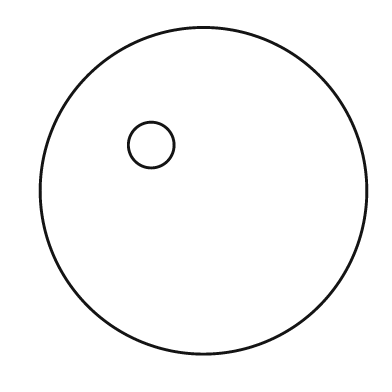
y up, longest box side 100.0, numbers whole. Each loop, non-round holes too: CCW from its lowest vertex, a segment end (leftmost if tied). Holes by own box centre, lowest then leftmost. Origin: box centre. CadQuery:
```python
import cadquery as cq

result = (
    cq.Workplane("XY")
    .moveTo(0.0, 0.0)
    .circle(50.0)
    .moveTo(-16.0, 14.0)
    .circle(7.0)
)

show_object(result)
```